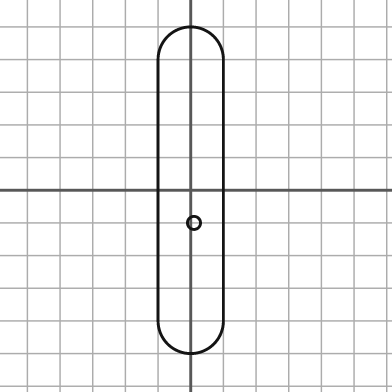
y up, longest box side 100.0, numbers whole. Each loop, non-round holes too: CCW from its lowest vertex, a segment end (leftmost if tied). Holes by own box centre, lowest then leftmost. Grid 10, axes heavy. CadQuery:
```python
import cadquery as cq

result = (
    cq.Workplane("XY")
    .moveTo(-10.0, -40.0)
    .threePointArc((0.0, -50.0), (10.0, -40.0))
    .lineTo(10.0, 40.0)
    .threePointArc((0.0, 50.0), (-10.0, 40.0))
    .close()
    .moveTo(1.0, -10.0)
    .circle(2.0)
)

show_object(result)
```